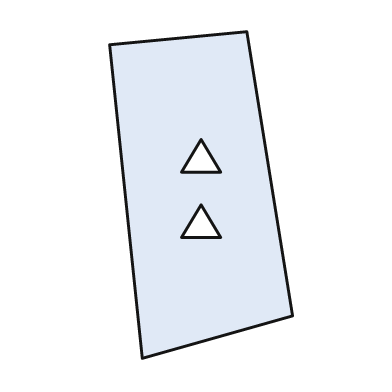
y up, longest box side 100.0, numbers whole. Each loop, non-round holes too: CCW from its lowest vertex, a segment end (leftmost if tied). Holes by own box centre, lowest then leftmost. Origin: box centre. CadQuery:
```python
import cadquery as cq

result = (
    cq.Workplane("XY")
    .moveTo(-18.0, -50.0)
    .lineTo(28.0, -37.0)
    .lineTo(14.0, 50.0)
    .lineTo(-28.0, 46.0)
    .close()
    .moveTo(-6.0, -13.0)
    .lineTo(6.0, -13.0)
    .lineTo(0.0, -3.0)
    .close()
    .moveTo(-6.0, 7.0)
    .lineTo(6.0, 7.0)
    .lineTo(0.0, 17.0)
    .close()
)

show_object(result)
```